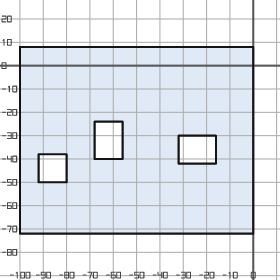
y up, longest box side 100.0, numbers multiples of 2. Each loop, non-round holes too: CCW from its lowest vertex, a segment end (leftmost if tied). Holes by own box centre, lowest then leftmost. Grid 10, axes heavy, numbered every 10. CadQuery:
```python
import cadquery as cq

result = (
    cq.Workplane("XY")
    .moveTo(-100.0, -72.0)
    .lineTo(0.0, -72.0)
    .lineTo(0.0, 8.0)
    .lineTo(-100.0, 8.0)
    .close()
    .moveTo(-92.0, -50.0)
    .lineTo(-80.0, -50.0)
    .lineTo(-80.0, -38.0)
    .lineTo(-92.0, -38.0)
    .close()
    .moveTo(-32.0, -42.0)
    .lineTo(-16.0, -42.0)
    .lineTo(-16.0, -30.0)
    .lineTo(-32.0, -30.0)
    .close()
    .moveTo(-68.0, -40.0)
    .lineTo(-56.0, -40.0)
    .lineTo(-56.0, -24.0)
    .lineTo(-68.0, -24.0)
    .close()
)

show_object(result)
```